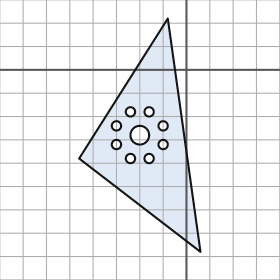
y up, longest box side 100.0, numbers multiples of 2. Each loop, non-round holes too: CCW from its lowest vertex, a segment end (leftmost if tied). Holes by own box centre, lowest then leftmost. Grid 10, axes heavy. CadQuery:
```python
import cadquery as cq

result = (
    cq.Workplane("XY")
    .moveTo(6.0, -78.0)
    .lineTo(-8.0, 22.0)
    .lineTo(-46.0, -38.0)
    .close()
    .moveTo(-24.0, -38.0)
    .circle(2.0)
    .moveTo(-16.0, -38.0)
    .circle(2.0)
    .moveTo(-30.0, -32.0)
    .circle(2.0)
    .moveTo(-10.0, -32.0)
    .circle(2.0)
    .moveTo(-20.0, -28.0)
    .circle(4.0)
    .moveTo(-30.0, -24.0)
    .circle(2.0)
    .moveTo(-10.0, -24.0)
    .circle(2.0)
    .moveTo(-24.0, -18.0)
    .circle(2.0)
    .moveTo(-16.0, -18.0)
    .circle(2.0)
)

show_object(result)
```